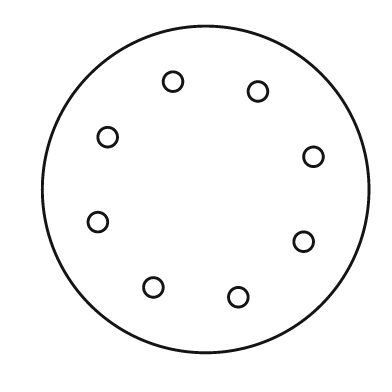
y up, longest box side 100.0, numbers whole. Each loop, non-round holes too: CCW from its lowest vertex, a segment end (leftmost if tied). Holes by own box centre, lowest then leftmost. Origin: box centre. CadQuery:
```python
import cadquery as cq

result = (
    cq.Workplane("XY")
    .moveTo(0.0, 0.0)
    .circle(50.0)
    .moveTo(10.0, -33.0)
    .circle(3.0)
    .moveTo(-16.0, -30.0)
    .circle(3.0)
    .moveTo(30.0, -16.0)
    .circle(3.0)
    .moveTo(-33.0, -10.0)
    .circle(3.0)
    .moveTo(33.0, 10.0)
    .circle(3.0)
    .moveTo(-30.0, 16.0)
    .circle(3.0)
    .moveTo(16.0, 30.0)
    .circle(3.0)
    .moveTo(-10.0, 33.0)
    .circle(3.0)
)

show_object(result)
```